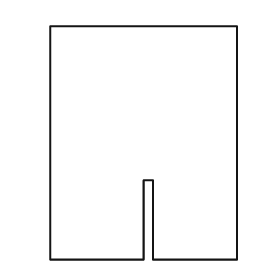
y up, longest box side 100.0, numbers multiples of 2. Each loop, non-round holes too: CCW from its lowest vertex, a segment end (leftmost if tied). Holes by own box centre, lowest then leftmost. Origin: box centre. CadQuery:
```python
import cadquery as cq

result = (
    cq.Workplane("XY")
    .moveTo(-40.0, -50.0)
    .lineTo(0.0, -50.0)
    .lineTo(0.0, -16.0)
    .lineTo(4.0, -16.0)
    .lineTo(4.0, -50.0)
    .lineTo(40.0, -50.0)
    .lineTo(40.0, 50.0)
    .lineTo(-40.0, 50.0)
    .close()
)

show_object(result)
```